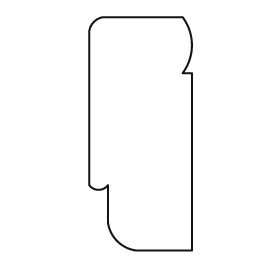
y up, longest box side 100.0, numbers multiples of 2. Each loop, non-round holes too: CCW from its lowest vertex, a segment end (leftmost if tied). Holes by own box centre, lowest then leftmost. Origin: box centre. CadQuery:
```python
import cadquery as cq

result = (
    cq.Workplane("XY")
    .moveTo(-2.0, -50.0)
    .lineTo(22.0, -50.0)
    .lineTo(22.0, 26.0)
    .lineTo(18.0, 26.0)
    .threePointArc((22.0, 38.0), (18.0, 50.0))
    .lineTo(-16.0, 50.0)
    .threePointArc((-20.0, 48.0), (-22.0, 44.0))
    .lineTo(-22.0, -22.0)
    .threePointArc((-18.0, -24.0), (-14.0, -22.0))
    .lineTo(-14.0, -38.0)
    .threePointArc((-10.0, -46.0), (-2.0, -50.0))
    .close()
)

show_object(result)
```